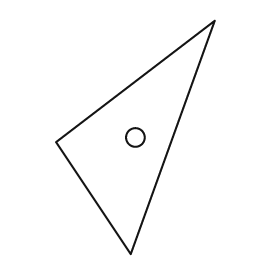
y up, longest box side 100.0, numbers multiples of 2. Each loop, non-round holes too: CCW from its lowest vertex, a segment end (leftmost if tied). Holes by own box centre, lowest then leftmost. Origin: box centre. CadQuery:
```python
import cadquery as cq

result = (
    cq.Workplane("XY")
    .moveTo(-2.0, -50.0)
    .lineTo(34.0, 50.0)
    .lineTo(-34.0, -2.0)
    .close()
    .moveTo(0.0, 0.0)
    .circle(4.0)
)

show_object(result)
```